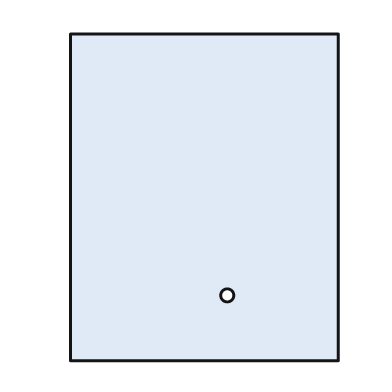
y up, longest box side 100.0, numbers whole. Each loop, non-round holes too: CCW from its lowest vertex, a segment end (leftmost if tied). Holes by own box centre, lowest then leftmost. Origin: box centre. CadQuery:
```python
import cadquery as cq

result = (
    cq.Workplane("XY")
    .moveTo(-41.0, -50.0)
    .lineTo(41.0, -50.0)
    .lineTo(41.0, 50.0)
    .lineTo(-41.0, 50.0)
    .close()
    .moveTo(7.0, -30.0)
    .circle(2.0)
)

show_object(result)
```